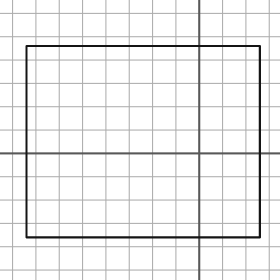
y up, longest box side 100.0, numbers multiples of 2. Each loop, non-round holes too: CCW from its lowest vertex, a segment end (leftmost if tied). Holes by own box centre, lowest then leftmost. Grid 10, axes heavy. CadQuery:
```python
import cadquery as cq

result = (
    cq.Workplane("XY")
    .moveTo(-74.0, -36.0)
    .lineTo(26.0, -36.0)
    .lineTo(26.0, 46.0)
    .lineTo(-74.0, 46.0)
    .close()
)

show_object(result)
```